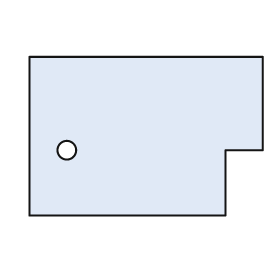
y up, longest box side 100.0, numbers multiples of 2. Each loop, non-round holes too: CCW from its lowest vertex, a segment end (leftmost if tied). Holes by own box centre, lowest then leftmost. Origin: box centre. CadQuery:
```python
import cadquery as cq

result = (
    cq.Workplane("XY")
    .moveTo(-50.0, -34.0)
    .lineTo(34.0, -34.0)
    .lineTo(34.0, -6.0)
    .lineTo(50.0, -6.0)
    .lineTo(50.0, 34.0)
    .lineTo(-50.0, 34.0)
    .close()
    .moveTo(-34.0, -6.0)
    .circle(4.0)
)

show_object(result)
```